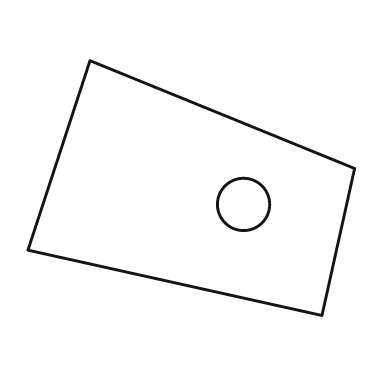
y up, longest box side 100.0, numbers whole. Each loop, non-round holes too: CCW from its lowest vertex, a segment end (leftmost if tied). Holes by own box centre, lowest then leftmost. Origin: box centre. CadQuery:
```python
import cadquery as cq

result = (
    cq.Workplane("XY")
    .moveTo(40.0, -39.0)
    .lineTo(50.0, 6.0)
    .lineTo(-31.0, 39.0)
    .lineTo(-50.0, -19.0)
    .close()
    .moveTo(16.0, -5.0)
    .circle(8.0)
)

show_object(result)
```